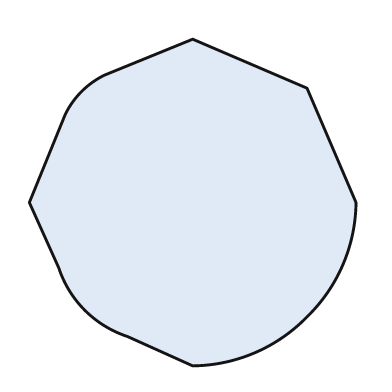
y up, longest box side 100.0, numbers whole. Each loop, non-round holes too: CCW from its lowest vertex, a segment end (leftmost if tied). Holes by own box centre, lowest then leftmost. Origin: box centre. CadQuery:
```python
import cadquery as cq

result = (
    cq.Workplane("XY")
    .moveTo(0.0, -50.0)
    .threePointArc((19.0, -46.0), (35.0, -35.0))
    .threePointArc((46.0, -19.0), (50.0, 0.0))
    .lineTo(35.0, 35.0)
    .lineTo(0.0, 50.0)
    .lineTo(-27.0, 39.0)
    .threePointArc((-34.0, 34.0), (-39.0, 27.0))
    .lineTo(-50.0, 0.0)
    .lineTo(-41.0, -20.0)
    .threePointArc((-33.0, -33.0), (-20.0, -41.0))
    .close()
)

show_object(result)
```